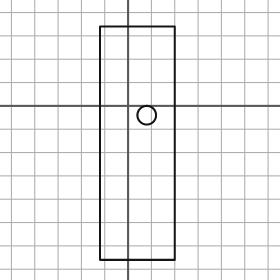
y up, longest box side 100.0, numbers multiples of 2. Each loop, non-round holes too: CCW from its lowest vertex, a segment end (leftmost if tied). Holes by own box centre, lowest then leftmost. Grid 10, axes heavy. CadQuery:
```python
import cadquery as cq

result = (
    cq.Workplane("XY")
    .moveTo(-12.0, -66.0)
    .lineTo(20.0, -66.0)
    .lineTo(20.0, 34.0)
    .lineTo(-12.0, 34.0)
    .close()
    .moveTo(8.0, -4.0)
    .circle(4.0)
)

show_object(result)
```